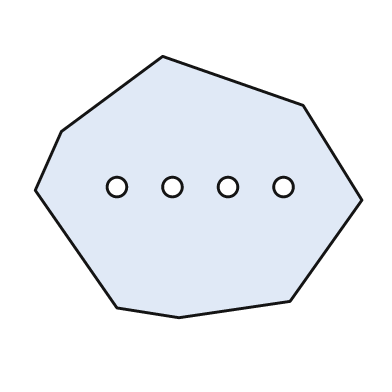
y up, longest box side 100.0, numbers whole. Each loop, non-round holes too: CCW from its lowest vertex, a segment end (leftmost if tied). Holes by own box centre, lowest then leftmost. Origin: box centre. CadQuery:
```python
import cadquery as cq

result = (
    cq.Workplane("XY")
    .moveTo(-6.0, -40.0)
    .lineTo(28.0, -35.0)
    .lineTo(50.0, -4.0)
    .lineTo(32.0, 25.0)
    .lineTo(-11.0, 40.0)
    .lineTo(-42.0, 17.0)
    .lineTo(-50.0, -1.0)
    .lineTo(-25.0, -37.0)
    .close()
    .moveTo(-25.0, 0.0)
    .circle(3.0)
    .moveTo(-8.0, 0.0)
    .circle(3.0)
    .moveTo(9.0, 0.0)
    .circle(3.0)
    .moveTo(26.0, 0.0)
    .circle(3.0)
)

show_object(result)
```